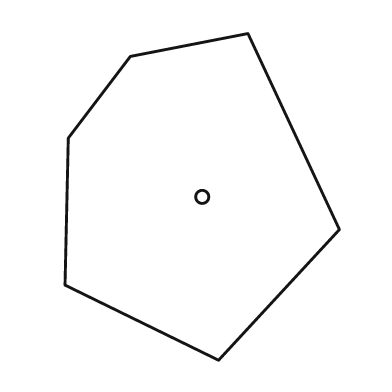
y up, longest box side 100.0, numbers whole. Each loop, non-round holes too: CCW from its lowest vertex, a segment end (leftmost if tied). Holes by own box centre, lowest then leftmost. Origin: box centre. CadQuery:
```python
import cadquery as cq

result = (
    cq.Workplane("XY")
    .moveTo(5.0, -50.0)
    .lineTo(42.0, -10.0)
    .lineTo(14.0, 50.0)
    .lineTo(-22.0, 43.0)
    .lineTo(-41.0, 18.0)
    .lineTo(-42.0, -27.0)
    .close()
    .moveTo(0.0, 0.0)
    .circle(2.0)
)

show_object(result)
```